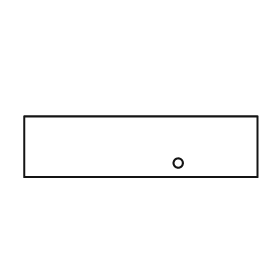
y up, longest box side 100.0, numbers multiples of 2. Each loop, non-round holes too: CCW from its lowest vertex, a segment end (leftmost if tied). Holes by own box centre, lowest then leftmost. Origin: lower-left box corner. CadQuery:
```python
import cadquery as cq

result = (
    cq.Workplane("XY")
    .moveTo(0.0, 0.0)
    .lineTo(100.0, 0.0)
    .lineTo(100.0, 26.0)
    .lineTo(0.0, 26.0)
    .close()
    .moveTo(66.0, 6.0)
    .circle(2.0)
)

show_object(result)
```